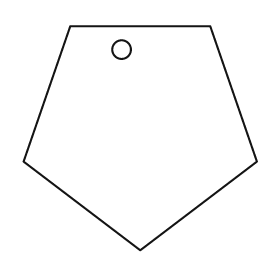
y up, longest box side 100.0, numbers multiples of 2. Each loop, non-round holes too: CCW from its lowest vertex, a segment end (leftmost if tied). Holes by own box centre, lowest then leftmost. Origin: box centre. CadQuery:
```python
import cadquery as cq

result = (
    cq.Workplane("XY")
    .moveTo(0.0, -48.0)
    .lineTo(50.0, -10.0)
    .lineTo(30.0, 48.0)
    .lineTo(-30.0, 48.0)
    .lineTo(-50.0, -10.0)
    .close()
    .moveTo(-8.0, 38.0)
    .circle(4.0)
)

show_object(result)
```